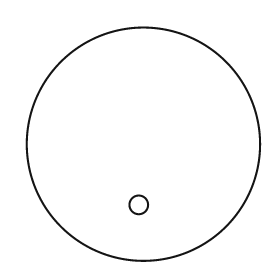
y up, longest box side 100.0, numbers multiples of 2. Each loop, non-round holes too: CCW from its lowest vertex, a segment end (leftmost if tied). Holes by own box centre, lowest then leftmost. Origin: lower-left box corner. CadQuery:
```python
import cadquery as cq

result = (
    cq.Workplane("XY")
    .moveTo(50.0, 50.0)
    .circle(50.0)
    .moveTo(48.0, 24.0)
    .circle(4.0)
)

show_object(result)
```